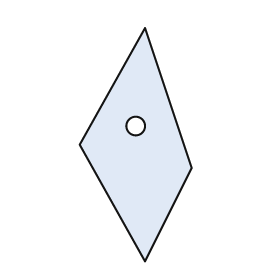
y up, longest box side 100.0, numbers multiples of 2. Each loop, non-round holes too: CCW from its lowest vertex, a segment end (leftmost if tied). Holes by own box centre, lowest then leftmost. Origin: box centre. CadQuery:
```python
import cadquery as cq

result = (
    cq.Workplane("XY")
    .moveTo(4.0, -50.0)
    .lineTo(24.0, -10.0)
    .lineTo(4.0, 50.0)
    .lineTo(-24.0, 0.0)
    .close()
    .moveTo(0.0, 8.0)
    .circle(4.0)
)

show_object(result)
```